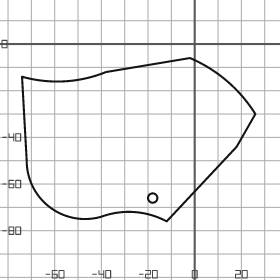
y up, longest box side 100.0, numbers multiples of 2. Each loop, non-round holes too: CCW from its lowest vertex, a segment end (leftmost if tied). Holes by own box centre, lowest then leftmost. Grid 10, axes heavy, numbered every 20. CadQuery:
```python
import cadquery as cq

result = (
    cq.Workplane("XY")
    .moveTo(-12.0, -76.0)
    .lineTo(18.0, -44.0)
    .lineTo(26.0, -30.0)
    .threePointArc((14.0, -16.0), (-2.0, -6.0))
    .lineTo(-38.0, -12.0)
    .threePointArc((-56.0, -16.0), (-74.0, -14.0))
    .lineTo(-72.0, -50.0)
    .threePointArc((-62.0, -70.0), (-40.0, -74.0))
    .threePointArc((-26.0, -72.0), (-12.0, -76.0))
    .close()
    .moveTo(-18.0, -66.0)
    .circle(2.0)
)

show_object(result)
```